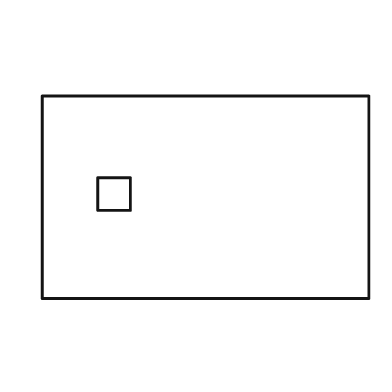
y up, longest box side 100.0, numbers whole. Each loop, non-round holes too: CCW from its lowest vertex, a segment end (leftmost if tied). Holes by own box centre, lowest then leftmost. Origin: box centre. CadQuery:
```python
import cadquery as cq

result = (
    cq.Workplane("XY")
    .moveTo(-50.0, -31.0)
    .lineTo(50.0, -31.0)
    .lineTo(50.0, 31.0)
    .lineTo(-50.0, 31.0)
    .close()
    .moveTo(-33.0, -4.0)
    .lineTo(-23.0, -4.0)
    .lineTo(-23.0, 6.0)
    .lineTo(-33.0, 6.0)
    .close()
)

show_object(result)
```